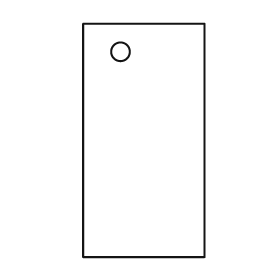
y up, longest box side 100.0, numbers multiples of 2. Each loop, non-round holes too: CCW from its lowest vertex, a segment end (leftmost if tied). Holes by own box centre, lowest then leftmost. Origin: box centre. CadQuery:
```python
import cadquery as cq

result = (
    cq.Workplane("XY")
    .moveTo(-26.0, -50.0)
    .lineTo(26.0, -50.0)
    .lineTo(26.0, 50.0)
    .lineTo(-26.0, 50.0)
    .close()
    .moveTo(-10.0, 38.0)
    .circle(4.0)
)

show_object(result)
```